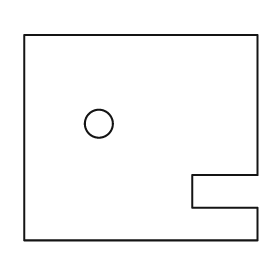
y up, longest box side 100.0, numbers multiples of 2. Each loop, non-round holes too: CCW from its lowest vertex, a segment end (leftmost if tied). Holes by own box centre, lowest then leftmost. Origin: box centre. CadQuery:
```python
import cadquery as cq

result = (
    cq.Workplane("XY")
    .moveTo(-50.0, -44.0)
    .lineTo(50.0, -44.0)
    .lineTo(50.0, -30.0)
    .lineTo(22.0, -30.0)
    .lineTo(22.0, -16.0)
    .lineTo(50.0, -16.0)
    .lineTo(50.0, 44.0)
    .lineTo(-50.0, 44.0)
    .close()
    .moveTo(-18.0, 6.0)
    .circle(6.0)
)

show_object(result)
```